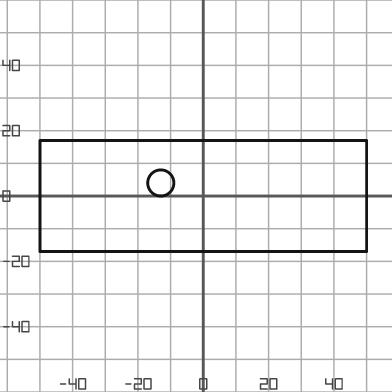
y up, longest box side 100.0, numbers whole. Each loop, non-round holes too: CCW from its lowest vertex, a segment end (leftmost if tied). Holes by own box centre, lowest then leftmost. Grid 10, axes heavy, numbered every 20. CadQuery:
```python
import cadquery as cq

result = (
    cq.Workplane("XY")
    .moveTo(-50.0, -17.0)
    .lineTo(50.0, -17.0)
    .lineTo(50.0, 17.0)
    .lineTo(-50.0, 17.0)
    .close()
    .moveTo(-13.0, 4.0)
    .circle(4.0)
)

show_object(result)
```